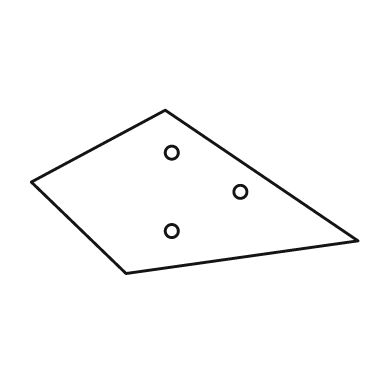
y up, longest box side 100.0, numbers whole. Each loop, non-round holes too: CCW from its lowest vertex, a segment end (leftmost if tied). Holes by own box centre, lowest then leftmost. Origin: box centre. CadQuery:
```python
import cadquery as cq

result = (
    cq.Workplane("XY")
    .moveTo(-21.0, -25.0)
    .lineTo(50.0, -15.0)
    .lineTo(-9.0, 25.0)
    .lineTo(-50.0, 3.0)
    .close()
    .moveTo(-7.0, -12.0)
    .circle(2.0)
    .moveTo(14.0, 0.0)
    .circle(2.0)
    .moveTo(-7.0, 12.0)
    .circle(2.0)
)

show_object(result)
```